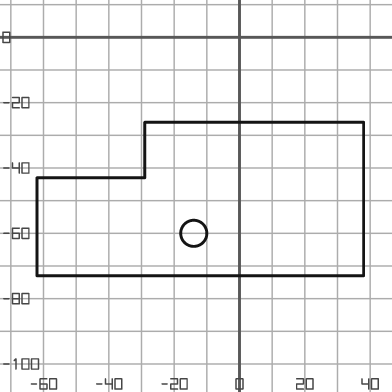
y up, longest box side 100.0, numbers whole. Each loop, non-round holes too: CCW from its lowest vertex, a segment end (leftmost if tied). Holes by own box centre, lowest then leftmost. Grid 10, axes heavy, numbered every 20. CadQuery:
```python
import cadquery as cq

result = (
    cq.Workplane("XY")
    .moveTo(-62.0, -73.0)
    .lineTo(38.0, -73.0)
    .lineTo(38.0, -26.0)
    .lineTo(-29.0, -26.0)
    .lineTo(-29.0, -43.0)
    .lineTo(-62.0, -43.0)
    .close()
    .moveTo(-14.0, -60.0)
    .circle(4.0)
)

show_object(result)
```